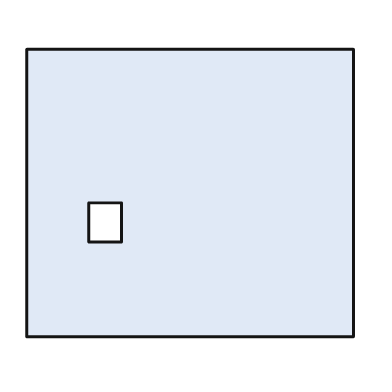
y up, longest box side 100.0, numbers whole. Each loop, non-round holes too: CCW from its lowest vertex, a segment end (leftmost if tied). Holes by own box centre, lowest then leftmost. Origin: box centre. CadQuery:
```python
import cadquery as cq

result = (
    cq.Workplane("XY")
    .moveTo(-50.0, -44.0)
    .lineTo(50.0, -44.0)
    .lineTo(50.0, 44.0)
    .lineTo(-50.0, 44.0)
    .close()
    .moveTo(-31.0, -15.0)
    .lineTo(-21.0, -15.0)
    .lineTo(-21.0, -3.0)
    .lineTo(-31.0, -3.0)
    .close()
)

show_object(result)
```